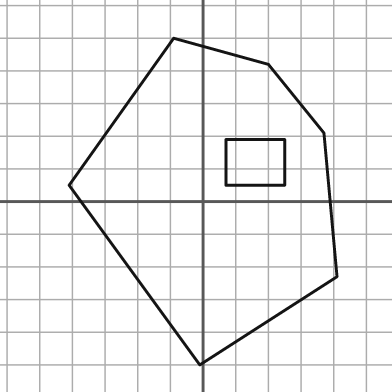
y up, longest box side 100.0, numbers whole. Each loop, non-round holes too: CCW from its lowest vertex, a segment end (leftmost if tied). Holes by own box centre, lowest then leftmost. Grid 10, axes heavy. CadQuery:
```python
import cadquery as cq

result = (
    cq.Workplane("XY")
    .moveTo(-1.0, -50.0)
    .lineTo(41.0, -23.0)
    .lineTo(37.0, 21.0)
    .lineTo(20.0, 42.0)
    .lineTo(-9.0, 50.0)
    .lineTo(-41.0, 5.0)
    .close()
    .moveTo(7.0, 5.0)
    .lineTo(25.0, 5.0)
    .lineTo(25.0, 19.0)
    .lineTo(7.0, 19.0)
    .close()
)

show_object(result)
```